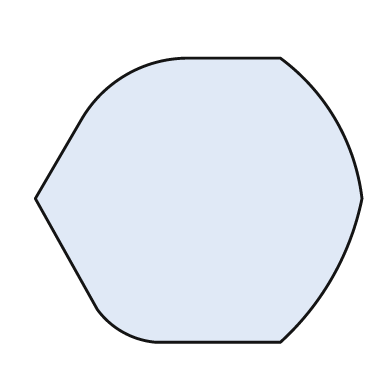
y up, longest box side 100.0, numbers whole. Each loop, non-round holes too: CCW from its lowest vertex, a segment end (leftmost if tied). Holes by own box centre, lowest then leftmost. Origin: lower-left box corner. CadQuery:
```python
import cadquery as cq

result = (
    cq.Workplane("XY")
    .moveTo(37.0, 0.0)
    .lineTo(75.0, 0.0)
    .threePointArc((91.0, 20.0), (100.0, 44.0))
    .threePointArc((92.0, 68.0), (75.0, 87.0))
    .lineTo(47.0, 87.0)
    .threePointArc((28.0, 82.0), (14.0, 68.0))
    .lineTo(0.0, 44.0)
    .lineTo(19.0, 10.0)
    .threePointArc((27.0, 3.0), (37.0, 0.0))
    .close()
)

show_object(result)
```